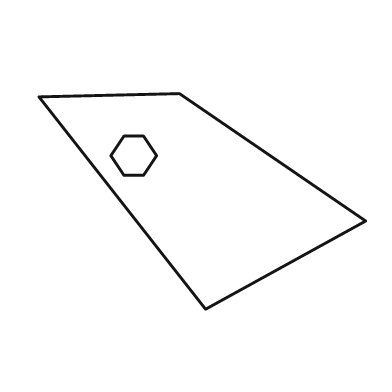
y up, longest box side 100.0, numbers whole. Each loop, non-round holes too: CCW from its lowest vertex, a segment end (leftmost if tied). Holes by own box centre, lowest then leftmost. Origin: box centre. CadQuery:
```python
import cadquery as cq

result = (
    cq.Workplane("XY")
    .moveTo(1.0, -33.0)
    .lineTo(50.0, -6.0)
    .lineTo(-7.0, 33.0)
    .lineTo(-50.0, 32.0)
    .close()
    .moveTo(-24.0, 8.0)
    .lineTo(-18.0, 8.0)
    .lineTo(-14.0, 14.0)
    .lineTo(-18.0, 20.0)
    .lineTo(-24.0, 20.0)
    .lineTo(-28.0, 14.0)
    .close()
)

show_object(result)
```